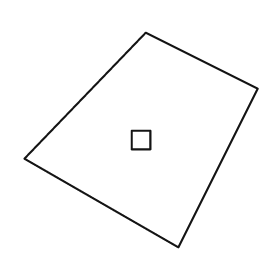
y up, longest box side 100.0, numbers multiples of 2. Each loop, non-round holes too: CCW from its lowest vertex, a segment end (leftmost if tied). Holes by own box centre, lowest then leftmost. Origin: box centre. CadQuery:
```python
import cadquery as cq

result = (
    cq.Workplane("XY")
    .moveTo(16.0, -46.0)
    .lineTo(50.0, 22.0)
    .lineTo(2.0, 46.0)
    .lineTo(-50.0, -8.0)
    .close()
    .moveTo(-4.0, -4.0)
    .lineTo(4.0, -4.0)
    .lineTo(4.0, 4.0)
    .lineTo(-4.0, 4.0)
    .close()
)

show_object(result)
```